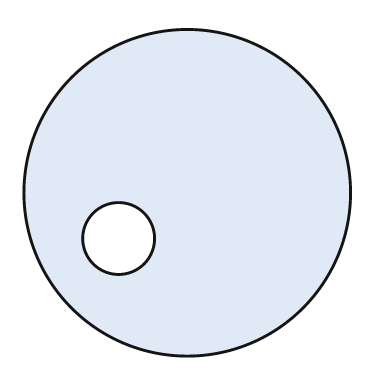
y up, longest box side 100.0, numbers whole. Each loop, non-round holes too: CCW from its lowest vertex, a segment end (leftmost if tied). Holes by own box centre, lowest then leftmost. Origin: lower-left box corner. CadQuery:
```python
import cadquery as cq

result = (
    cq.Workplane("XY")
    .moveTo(50.0, 50.0)
    .circle(50.0)
    .moveTo(29.0, 36.0)
    .circle(11.0)
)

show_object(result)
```